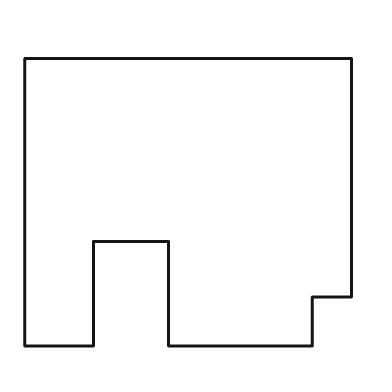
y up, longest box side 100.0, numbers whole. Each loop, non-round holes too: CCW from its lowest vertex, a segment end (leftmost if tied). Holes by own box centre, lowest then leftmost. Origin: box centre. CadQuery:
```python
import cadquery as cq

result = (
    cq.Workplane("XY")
    .moveTo(-50.0, -44.0)
    .lineTo(-29.0, -44.0)
    .lineTo(-29.0, -12.0)
    .lineTo(-6.0, -12.0)
    .lineTo(-6.0, -44.0)
    .lineTo(38.0, -44.0)
    .lineTo(38.0, -29.0)
    .lineTo(50.0, -29.0)
    .lineTo(50.0, 44.0)
    .lineTo(-50.0, 44.0)
    .close()
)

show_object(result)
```